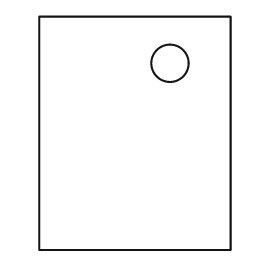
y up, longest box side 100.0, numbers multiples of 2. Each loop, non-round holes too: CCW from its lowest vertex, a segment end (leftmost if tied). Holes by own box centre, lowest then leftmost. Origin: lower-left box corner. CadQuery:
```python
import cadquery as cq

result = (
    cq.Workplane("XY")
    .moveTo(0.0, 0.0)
    .lineTo(82.0, 0.0)
    .lineTo(82.0, 100.0)
    .lineTo(0.0, 100.0)
    .close()
    .moveTo(56.0, 80.0)
    .circle(8.0)
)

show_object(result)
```